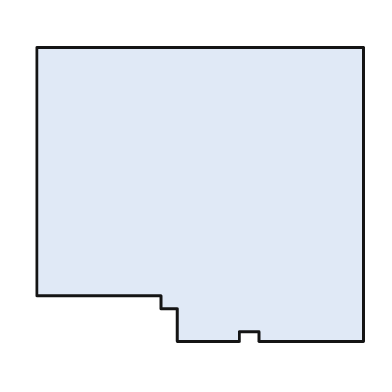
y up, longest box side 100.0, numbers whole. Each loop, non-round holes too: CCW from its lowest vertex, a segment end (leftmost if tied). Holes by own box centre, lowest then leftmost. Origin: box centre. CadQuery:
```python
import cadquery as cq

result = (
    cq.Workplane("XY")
    .moveTo(-7.0, -45.0)
    .lineTo(12.0, -45.0)
    .lineTo(12.0, -42.0)
    .lineTo(18.0, -42.0)
    .lineTo(18.0, -45.0)
    .lineTo(50.0, -45.0)
    .lineTo(50.0, 45.0)
    .lineTo(-50.0, 45.0)
    .lineTo(-50.0, -31.0)
    .lineTo(-12.0, -31.0)
    .lineTo(-12.0, -35.0)
    .lineTo(-7.0, -35.0)
    .close()
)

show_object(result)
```